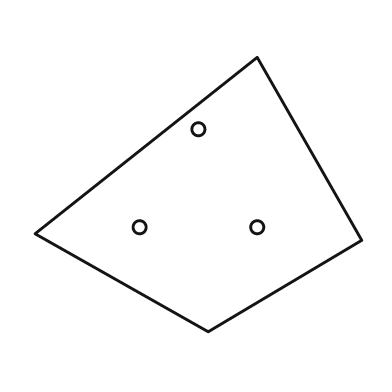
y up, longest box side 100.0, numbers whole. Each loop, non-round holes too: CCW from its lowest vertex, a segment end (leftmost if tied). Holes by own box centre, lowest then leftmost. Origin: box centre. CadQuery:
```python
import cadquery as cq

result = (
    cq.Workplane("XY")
    .moveTo(3.0, -42.0)
    .lineTo(50.0, -14.0)
    .lineTo(18.0, 42.0)
    .lineTo(-50.0, -12.0)
    .close()
    .moveTo(-18.0, -10.0)
    .circle(2.0)
    .moveTo(18.0, -10.0)
    .circle(2.0)
    .moveTo(0.0, 20.0)
    .circle(2.0)
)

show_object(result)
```